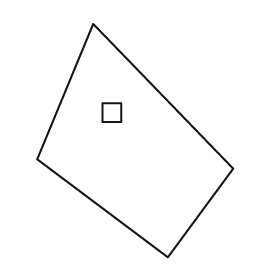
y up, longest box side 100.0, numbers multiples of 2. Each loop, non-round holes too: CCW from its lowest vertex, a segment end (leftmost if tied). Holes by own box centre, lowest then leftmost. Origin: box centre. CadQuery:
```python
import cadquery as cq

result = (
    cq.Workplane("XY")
    .moveTo(14.0, -50.0)
    .lineTo(42.0, -12.0)
    .lineTo(-18.0, 50.0)
    .lineTo(-42.0, -8.0)
    .close()
    .moveTo(-14.0, 8.0)
    .lineTo(-6.0, 8.0)
    .lineTo(-6.0, 16.0)
    .lineTo(-14.0, 16.0)
    .close()
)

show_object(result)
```